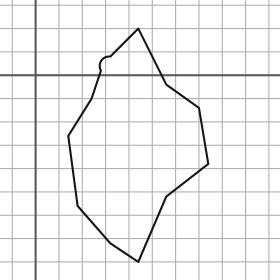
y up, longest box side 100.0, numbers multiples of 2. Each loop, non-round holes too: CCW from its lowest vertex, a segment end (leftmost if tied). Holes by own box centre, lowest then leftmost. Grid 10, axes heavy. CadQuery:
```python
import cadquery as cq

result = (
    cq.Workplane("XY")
    .moveTo(44.0, -80.0)
    .lineTo(56.0, -52.0)
    .lineTo(74.0, -38.0)
    .lineTo(70.0, -14.0)
    .lineTo(56.0, -4.0)
    .lineTo(44.0, 20.0)
    .lineTo(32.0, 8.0)
    .threePointArc((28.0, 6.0), (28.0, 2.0))
    .lineTo(24.0, -10.0)
    .lineTo(14.0, -26.0)
    .lineTo(18.0, -56.0)
    .lineTo(32.0, -72.0)
    .close()
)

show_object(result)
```